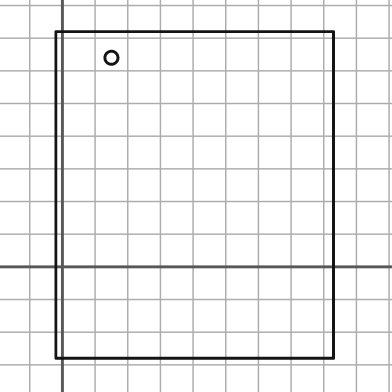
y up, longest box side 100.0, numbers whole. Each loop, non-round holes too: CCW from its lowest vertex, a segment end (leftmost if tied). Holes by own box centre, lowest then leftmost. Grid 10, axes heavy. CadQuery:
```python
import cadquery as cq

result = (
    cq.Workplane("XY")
    .moveTo(-2.0, -28.0)
    .lineTo(83.0, -28.0)
    .lineTo(83.0, 72.0)
    .lineTo(-2.0, 72.0)
    .close()
    .moveTo(15.0, 64.0)
    .circle(2.0)
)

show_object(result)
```